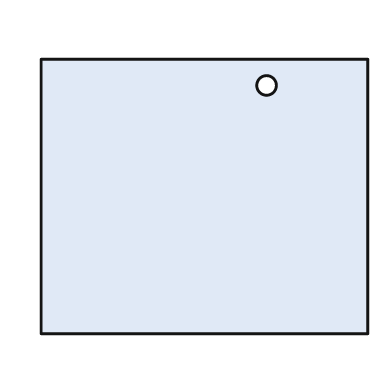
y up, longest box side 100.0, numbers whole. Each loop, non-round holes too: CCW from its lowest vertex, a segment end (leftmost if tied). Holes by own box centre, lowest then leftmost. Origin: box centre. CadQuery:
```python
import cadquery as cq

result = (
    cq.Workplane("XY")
    .moveTo(-50.0, -42.0)
    .lineTo(50.0, -42.0)
    .lineTo(50.0, 42.0)
    .lineTo(-50.0, 42.0)
    .close()
    .moveTo(19.0, 34.0)
    .circle(3.0)
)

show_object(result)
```